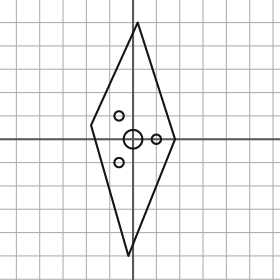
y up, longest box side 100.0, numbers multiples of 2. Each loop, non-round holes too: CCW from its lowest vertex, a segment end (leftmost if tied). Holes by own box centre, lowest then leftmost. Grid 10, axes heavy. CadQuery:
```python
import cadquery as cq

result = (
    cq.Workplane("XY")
    .moveTo(-2.0, -50.0)
    .lineTo(18.0, 0.0)
    .lineTo(2.0, 50.0)
    .lineTo(-18.0, 6.0)
    .close()
    .moveTo(-6.0, -10.0)
    .circle(2.0)
    .moveTo(0.0, 0.0)
    .circle(4.0)
    .moveTo(10.0, 0.0)
    .circle(2.0)
    .moveTo(-6.0, 10.0)
    .circle(2.0)
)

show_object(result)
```